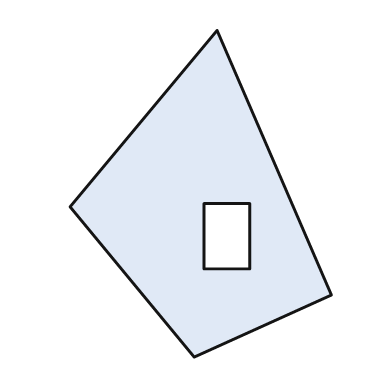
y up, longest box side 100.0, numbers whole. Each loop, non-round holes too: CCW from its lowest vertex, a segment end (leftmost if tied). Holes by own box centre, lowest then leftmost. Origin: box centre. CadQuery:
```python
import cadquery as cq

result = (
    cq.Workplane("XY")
    .moveTo(-2.0, -50.0)
    .lineTo(40.0, -31.0)
    .lineTo(5.0, 50.0)
    .lineTo(-40.0, -4.0)
    .close()
    .moveTo(1.0, -23.0)
    .lineTo(15.0, -23.0)
    .lineTo(15.0, -3.0)
    .lineTo(1.0, -3.0)
    .close()
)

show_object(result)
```